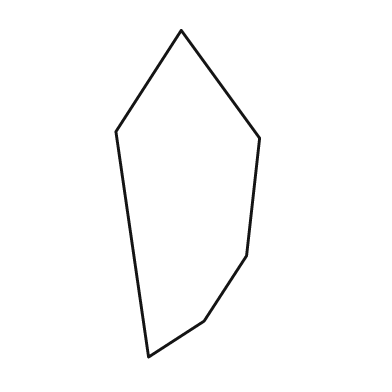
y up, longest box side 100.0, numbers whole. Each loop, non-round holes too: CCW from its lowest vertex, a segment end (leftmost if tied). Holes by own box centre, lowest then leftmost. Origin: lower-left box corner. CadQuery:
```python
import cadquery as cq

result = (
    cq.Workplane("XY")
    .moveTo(10.0, 0.0)
    .lineTo(27.0, 11.0)
    .lineTo(40.0, 31.0)
    .lineTo(44.0, 67.0)
    .lineTo(20.0, 100.0)
    .lineTo(0.0, 69.0)
    .close()
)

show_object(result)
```